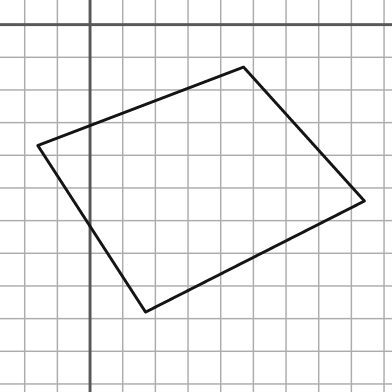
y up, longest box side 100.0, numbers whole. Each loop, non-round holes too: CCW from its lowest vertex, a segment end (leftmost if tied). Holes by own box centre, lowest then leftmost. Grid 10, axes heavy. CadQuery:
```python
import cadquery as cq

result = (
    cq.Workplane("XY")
    .moveTo(17.0, -88.0)
    .lineTo(84.0, -54.0)
    .lineTo(47.0, -13.0)
    .lineTo(-16.0, -37.0)
    .close()
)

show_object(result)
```